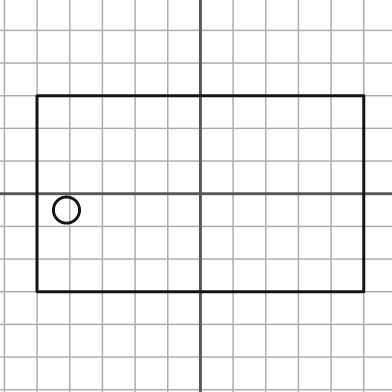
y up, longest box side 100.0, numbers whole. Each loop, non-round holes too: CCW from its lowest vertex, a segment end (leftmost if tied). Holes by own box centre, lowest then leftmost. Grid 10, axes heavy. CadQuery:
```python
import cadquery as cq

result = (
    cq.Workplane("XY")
    .moveTo(-50.0, -30.0)
    .lineTo(50.0, -30.0)
    .lineTo(50.0, 30.0)
    .lineTo(-50.0, 30.0)
    .close()
    .moveTo(-41.0, -5.0)
    .circle(4.0)
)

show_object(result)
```